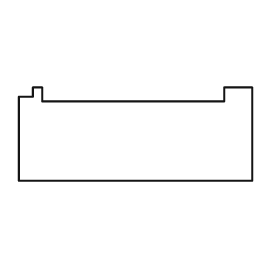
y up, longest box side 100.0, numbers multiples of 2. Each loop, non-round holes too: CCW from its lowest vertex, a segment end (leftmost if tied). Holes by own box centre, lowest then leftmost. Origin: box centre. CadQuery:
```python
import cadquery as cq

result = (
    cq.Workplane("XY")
    .moveTo(-50.0, -20.0)
    .lineTo(50.0, -20.0)
    .lineTo(50.0, 20.0)
    .lineTo(38.0, 20.0)
    .lineTo(38.0, 14.0)
    .lineTo(-40.0, 14.0)
    .lineTo(-40.0, 20.0)
    .lineTo(-44.0, 20.0)
    .lineTo(-44.0, 16.0)
    .lineTo(-50.0, 16.0)
    .close()
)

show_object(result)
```